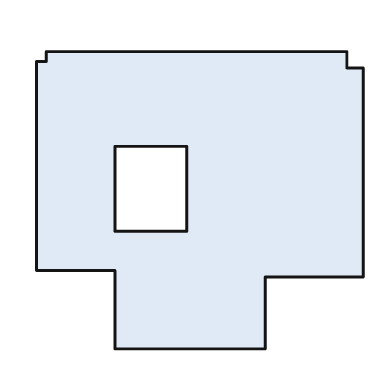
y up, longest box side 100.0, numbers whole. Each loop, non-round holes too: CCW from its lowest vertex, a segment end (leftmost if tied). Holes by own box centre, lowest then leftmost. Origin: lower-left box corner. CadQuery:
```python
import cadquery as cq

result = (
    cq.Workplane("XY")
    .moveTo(24.0, 0.0)
    .lineTo(70.0, 0.0)
    .lineTo(70.0, 22.0)
    .lineTo(100.0, 22.0)
    .lineTo(100.0, 86.0)
    .lineTo(95.0, 86.0)
    .lineTo(95.0, 91.0)
    .lineTo(3.0, 91.0)
    .lineTo(3.0, 88.0)
    .lineTo(0.0, 88.0)
    .lineTo(0.0, 24.0)
    .lineTo(24.0, 24.0)
    .close()
    .moveTo(24.0, 36.0)
    .lineTo(46.0, 36.0)
    .lineTo(46.0, 62.0)
    .lineTo(24.0, 62.0)
    .close()
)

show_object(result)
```